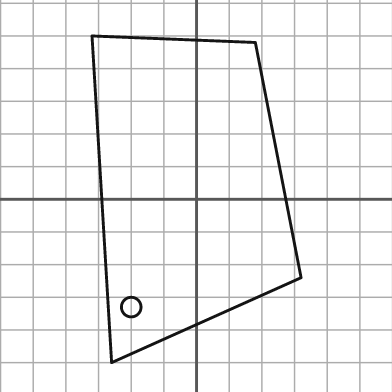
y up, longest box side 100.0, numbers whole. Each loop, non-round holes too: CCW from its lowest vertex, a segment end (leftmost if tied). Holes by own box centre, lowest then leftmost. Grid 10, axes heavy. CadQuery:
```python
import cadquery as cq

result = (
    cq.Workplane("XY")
    .moveTo(-26.0, -50.0)
    .lineTo(32.0, -24.0)
    .lineTo(18.0, 48.0)
    .lineTo(-32.0, 50.0)
    .close()
    .moveTo(-20.0, -33.0)
    .circle(3.0)
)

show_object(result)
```